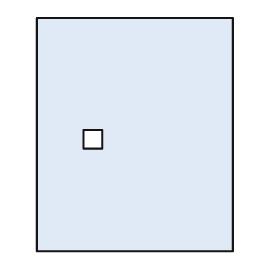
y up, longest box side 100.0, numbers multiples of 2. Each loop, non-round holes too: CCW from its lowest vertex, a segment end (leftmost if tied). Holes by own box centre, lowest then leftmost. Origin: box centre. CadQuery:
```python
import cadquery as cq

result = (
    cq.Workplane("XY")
    .moveTo(-42.0, -50.0)
    .lineTo(42.0, -50.0)
    .lineTo(42.0, 50.0)
    .lineTo(-42.0, 50.0)
    .close()
    .moveTo(-22.0, -6.0)
    .lineTo(-14.0, -6.0)
    .lineTo(-14.0, 2.0)
    .lineTo(-22.0, 2.0)
    .close()
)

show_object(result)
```